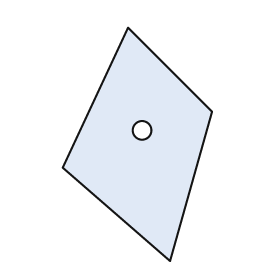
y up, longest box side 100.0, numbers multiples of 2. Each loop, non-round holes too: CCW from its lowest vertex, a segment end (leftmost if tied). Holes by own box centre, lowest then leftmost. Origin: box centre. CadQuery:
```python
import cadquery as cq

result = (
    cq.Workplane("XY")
    .moveTo(14.0, -50.0)
    .lineTo(32.0, 14.0)
    .lineTo(-4.0, 50.0)
    .lineTo(-32.0, -10.0)
    .close()
    .moveTo(2.0, 6.0)
    .circle(4.0)
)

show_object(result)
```